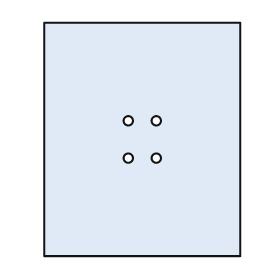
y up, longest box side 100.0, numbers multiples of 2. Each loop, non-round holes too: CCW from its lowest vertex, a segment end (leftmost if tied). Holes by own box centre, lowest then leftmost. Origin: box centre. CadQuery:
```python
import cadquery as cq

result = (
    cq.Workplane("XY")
    .moveTo(-42.0, -50.0)
    .lineTo(42.0, -50.0)
    .lineTo(42.0, 50.0)
    .lineTo(-42.0, 50.0)
    .close()
    .moveTo(-6.0, -8.0)
    .circle(2.0)
    .moveTo(6.0, -8.0)
    .circle(2.0)
    .moveTo(-6.0, 8.0)
    .circle(2.0)
    .moveTo(6.0, 8.0)
    .circle(2.0)
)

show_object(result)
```